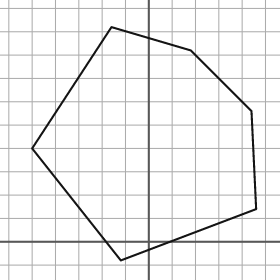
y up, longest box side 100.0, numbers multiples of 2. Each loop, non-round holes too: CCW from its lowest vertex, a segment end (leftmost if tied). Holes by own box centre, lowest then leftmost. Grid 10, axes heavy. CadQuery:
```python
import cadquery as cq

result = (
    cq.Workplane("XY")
    .moveTo(-12.0, -8.0)
    .lineTo(46.0, 14.0)
    .lineTo(44.0, 56.0)
    .lineTo(18.0, 82.0)
    .lineTo(-16.0, 92.0)
    .lineTo(-50.0, 40.0)
    .close()
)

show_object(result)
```